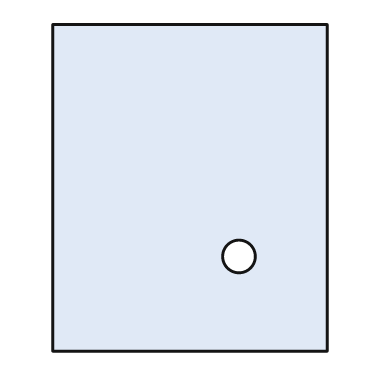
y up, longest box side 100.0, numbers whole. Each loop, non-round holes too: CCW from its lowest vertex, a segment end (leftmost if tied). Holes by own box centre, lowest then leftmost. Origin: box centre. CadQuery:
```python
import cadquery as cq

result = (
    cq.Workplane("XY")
    .moveTo(-42.0, -50.0)
    .lineTo(42.0, -50.0)
    .lineTo(42.0, 50.0)
    .lineTo(-42.0, 50.0)
    .close()
    .moveTo(15.0, -21.0)
    .circle(5.0)
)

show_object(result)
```